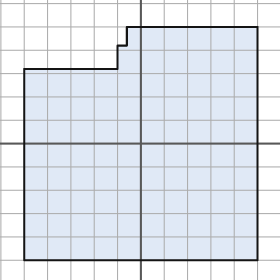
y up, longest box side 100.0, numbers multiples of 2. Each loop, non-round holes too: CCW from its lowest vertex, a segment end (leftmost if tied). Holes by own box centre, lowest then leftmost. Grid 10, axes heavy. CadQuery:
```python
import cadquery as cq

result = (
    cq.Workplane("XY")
    .moveTo(-50.0, -50.0)
    .lineTo(50.0, -50.0)
    .lineTo(50.0, 50.0)
    .lineTo(-6.0, 50.0)
    .lineTo(-6.0, 42.0)
    .lineTo(-10.0, 42.0)
    .lineTo(-10.0, 32.0)
    .lineTo(-50.0, 32.0)
    .close()
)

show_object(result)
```